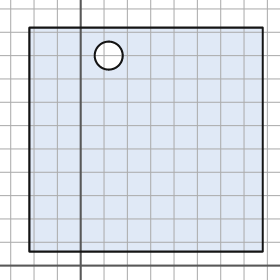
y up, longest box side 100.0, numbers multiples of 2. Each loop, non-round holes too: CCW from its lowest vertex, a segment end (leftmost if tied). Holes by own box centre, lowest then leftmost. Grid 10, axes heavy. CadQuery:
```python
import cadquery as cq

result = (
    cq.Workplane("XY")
    .moveTo(-22.0, 6.0)
    .lineTo(78.0, 6.0)
    .lineTo(78.0, 102.0)
    .lineTo(-22.0, 102.0)
    .close()
    .moveTo(12.0, 90.0)
    .circle(6.0)
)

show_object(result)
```